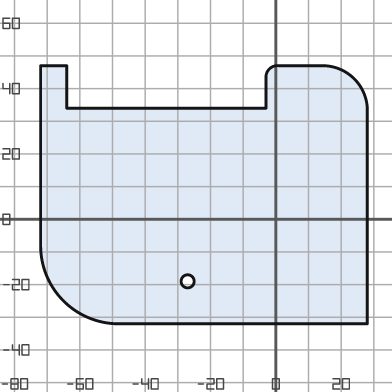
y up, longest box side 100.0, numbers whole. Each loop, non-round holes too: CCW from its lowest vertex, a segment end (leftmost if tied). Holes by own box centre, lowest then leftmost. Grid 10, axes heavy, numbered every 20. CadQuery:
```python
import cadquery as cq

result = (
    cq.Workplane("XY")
    .moveTo(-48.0, -32.0)
    .lineTo(28.0, -32.0)
    .lineTo(28.0, 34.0)
    .threePointArc((24.0, 43.0), (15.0, 47.0))
    .lineTo(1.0, 47.0)
    .threePointArc((-2.0, 46.0), (-3.0, 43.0))
    .lineTo(-3.0, 34.0)
    .lineTo(-64.0, 34.0)
    .lineTo(-64.0, 47.0)
    .lineTo(-72.0, 47.0)
    .lineTo(-72.0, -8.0)
    .threePointArc((-65.0, -25.0), (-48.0, -32.0))
    .close()
    .moveTo(-27.0, -19.0)
    .circle(2.0)
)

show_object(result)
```